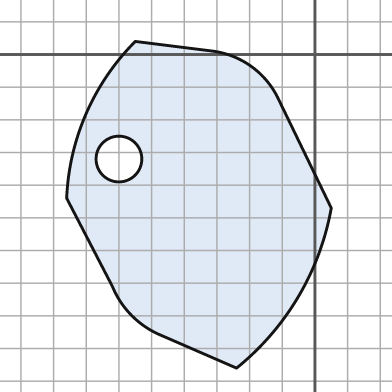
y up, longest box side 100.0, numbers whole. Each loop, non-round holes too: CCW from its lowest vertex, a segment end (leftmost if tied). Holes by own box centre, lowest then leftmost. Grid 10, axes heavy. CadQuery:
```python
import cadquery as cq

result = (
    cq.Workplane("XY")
    .moveTo(-24.0, -96.0)
    .threePointArc((-5.0, -74.0), (5.0, -47.0))
    .lineTo(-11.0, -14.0)
    .threePointArc((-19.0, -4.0), (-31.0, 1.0))
    .lineTo(-55.0, 4.0)
    .threePointArc((-70.0, -18.0), (-76.0, -44.0))
    .lineTo(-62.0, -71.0)
    .threePointArc((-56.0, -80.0), (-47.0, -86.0))
    .close()
    .moveTo(-60.0, -32.0)
    .circle(7.0)
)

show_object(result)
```